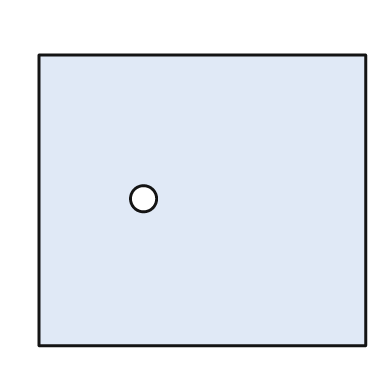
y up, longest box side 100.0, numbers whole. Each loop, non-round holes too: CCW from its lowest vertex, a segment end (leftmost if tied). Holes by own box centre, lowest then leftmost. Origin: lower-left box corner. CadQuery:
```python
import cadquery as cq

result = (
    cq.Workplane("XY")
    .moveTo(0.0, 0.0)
    .lineTo(100.0, 0.0)
    .lineTo(100.0, 89.0)
    .lineTo(0.0, 89.0)
    .close()
    .moveTo(32.0, 45.0)
    .circle(4.0)
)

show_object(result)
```